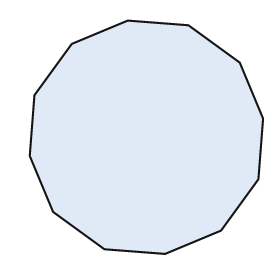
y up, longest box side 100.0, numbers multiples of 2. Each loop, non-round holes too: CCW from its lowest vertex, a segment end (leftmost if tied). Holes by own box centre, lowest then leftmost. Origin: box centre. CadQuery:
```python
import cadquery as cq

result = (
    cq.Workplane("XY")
    .moveTo(8.0, -50.0)
    .lineTo(32.0, -40.0)
    .lineTo(48.0, -18.0)
    .lineTo(50.0, 8.0)
    .lineTo(40.0, 32.0)
    .lineTo(18.0, 48.0)
    .lineTo(-8.0, 50.0)
    .lineTo(-32.0, 40.0)
    .lineTo(-48.0, 18.0)
    .lineTo(-50.0, -8.0)
    .lineTo(-40.0, -32.0)
    .lineTo(-18.0, -48.0)
    .close()
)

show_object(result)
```